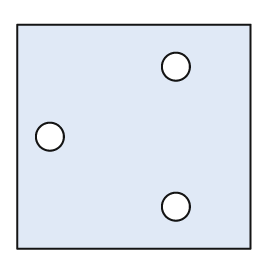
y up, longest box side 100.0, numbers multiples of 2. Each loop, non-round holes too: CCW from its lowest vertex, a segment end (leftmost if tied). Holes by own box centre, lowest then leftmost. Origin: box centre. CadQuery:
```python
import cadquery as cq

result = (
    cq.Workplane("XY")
    .moveTo(-50.0, -48.0)
    .lineTo(50.0, -48.0)
    .lineTo(50.0, 48.0)
    .lineTo(-50.0, 48.0)
    .close()
    .moveTo(18.0, -30.0)
    .circle(6.0)
    .moveTo(-36.0, 0.0)
    .circle(6.0)
    .moveTo(18.0, 30.0)
    .circle(6.0)
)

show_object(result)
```